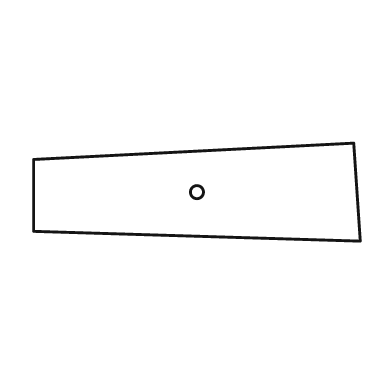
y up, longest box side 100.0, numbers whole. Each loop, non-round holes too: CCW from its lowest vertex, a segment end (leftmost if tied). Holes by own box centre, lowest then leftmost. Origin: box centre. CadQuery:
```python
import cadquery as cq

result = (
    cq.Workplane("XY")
    .moveTo(50.0, -15.0)
    .lineTo(48.0, 15.0)
    .lineTo(-50.0, 10.0)
    .lineTo(-50.0, -12.0)
    .close()
    .moveTo(0.0, 0.0)
    .circle(2.0)
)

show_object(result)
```